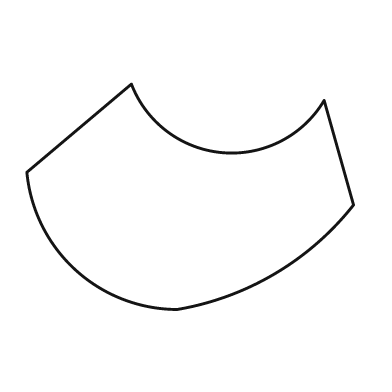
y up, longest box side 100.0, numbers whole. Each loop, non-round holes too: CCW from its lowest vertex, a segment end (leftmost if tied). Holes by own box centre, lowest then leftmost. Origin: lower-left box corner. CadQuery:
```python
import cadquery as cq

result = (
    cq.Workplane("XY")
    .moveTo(46.0, 0.0)
    .threePointArc((76.0, 11.0), (100.0, 32.0))
    .lineTo(91.0, 64.0)
    .threePointArc((60.0, 48.0), (32.0, 69.0))
    .lineTo(0.0, 42.0)
    .threePointArc((15.0, 12.0), (46.0, 0.0))
    .close()
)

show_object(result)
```